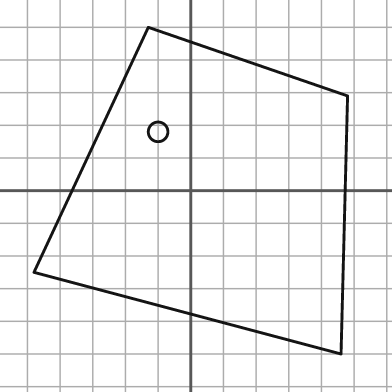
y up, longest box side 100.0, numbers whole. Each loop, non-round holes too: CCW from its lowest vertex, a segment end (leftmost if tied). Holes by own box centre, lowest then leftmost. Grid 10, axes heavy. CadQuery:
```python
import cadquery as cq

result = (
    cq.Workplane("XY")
    .moveTo(46.0, -50.0)
    .lineTo(48.0, 29.0)
    .lineTo(-13.0, 50.0)
    .lineTo(-48.0, -25.0)
    .close()
    .moveTo(-10.0, 18.0)
    .circle(3.0)
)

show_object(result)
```